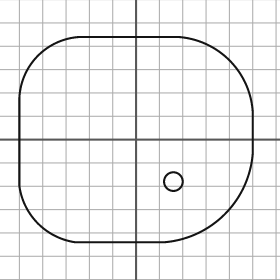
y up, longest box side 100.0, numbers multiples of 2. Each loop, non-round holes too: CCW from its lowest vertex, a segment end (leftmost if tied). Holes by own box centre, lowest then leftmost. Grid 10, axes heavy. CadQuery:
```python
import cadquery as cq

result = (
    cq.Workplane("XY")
    .moveTo(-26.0, -44.0)
    .lineTo(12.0, -44.0)
    .threePointArc((38.0, -32.0), (50.0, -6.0))
    .lineTo(50.0, 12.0)
    .threePointArc((40.0, 34.0), (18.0, 44.0))
    .lineTo(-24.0, 44.0)
    .threePointArc((-42.0, 36.0), (-50.0, 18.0))
    .lineTo(-50.0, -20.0)
    .threePointArc((-42.0, -36.0), (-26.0, -44.0))
    .close()
    .moveTo(16.0, -18.0)
    .circle(4.0)
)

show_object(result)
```